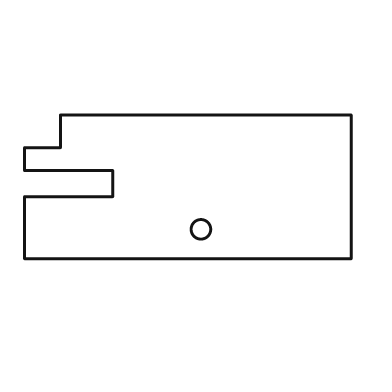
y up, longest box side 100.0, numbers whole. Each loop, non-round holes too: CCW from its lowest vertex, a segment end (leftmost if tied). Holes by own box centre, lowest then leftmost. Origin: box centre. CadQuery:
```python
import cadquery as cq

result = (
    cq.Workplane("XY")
    .moveTo(-50.0, -22.0)
    .lineTo(50.0, -22.0)
    .lineTo(50.0, 22.0)
    .lineTo(-39.0, 22.0)
    .lineTo(-39.0, 12.0)
    .lineTo(-50.0, 12.0)
    .lineTo(-50.0, 5.0)
    .lineTo(-23.0, 5.0)
    .lineTo(-23.0, -3.0)
    .lineTo(-50.0, -3.0)
    .close()
    .moveTo(4.0, -13.0)
    .circle(3.0)
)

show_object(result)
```